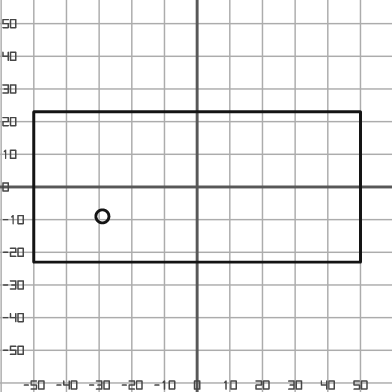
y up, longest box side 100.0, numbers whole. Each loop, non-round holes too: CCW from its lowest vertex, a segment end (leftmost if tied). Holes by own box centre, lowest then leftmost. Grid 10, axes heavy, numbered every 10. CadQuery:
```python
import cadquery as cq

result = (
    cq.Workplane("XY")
    .moveTo(-50.0, -23.0)
    .lineTo(50.0, -23.0)
    .lineTo(50.0, 23.0)
    .lineTo(-50.0, 23.0)
    .close()
    .moveTo(-29.0, -9.0)
    .circle(2.0)
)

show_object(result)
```